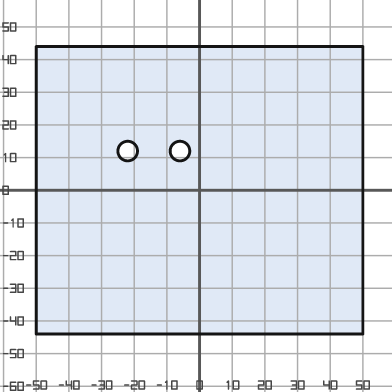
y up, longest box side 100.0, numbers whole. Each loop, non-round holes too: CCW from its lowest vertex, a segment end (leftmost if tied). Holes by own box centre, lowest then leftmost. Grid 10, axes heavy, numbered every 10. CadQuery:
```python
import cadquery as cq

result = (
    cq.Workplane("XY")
    .moveTo(-50.0, -44.0)
    .lineTo(50.0, -44.0)
    .lineTo(50.0, 44.0)
    .lineTo(-50.0, 44.0)
    .close()
    .moveTo(-22.0, 12.0)
    .circle(3.0)
    .moveTo(-6.0, 12.0)
    .circle(3.0)
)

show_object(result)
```